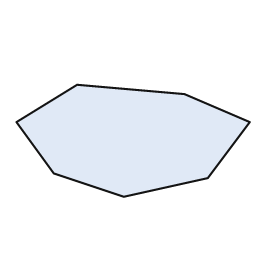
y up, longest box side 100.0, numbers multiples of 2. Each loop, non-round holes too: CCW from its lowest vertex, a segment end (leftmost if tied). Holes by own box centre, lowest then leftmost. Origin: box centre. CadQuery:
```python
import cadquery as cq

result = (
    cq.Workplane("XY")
    .moveTo(-4.0, -24.0)
    .lineTo(32.0, -16.0)
    .lineTo(50.0, 8.0)
    .lineTo(22.0, 20.0)
    .lineTo(-24.0, 24.0)
    .lineTo(-50.0, 8.0)
    .lineTo(-34.0, -14.0)
    .close()
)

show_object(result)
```